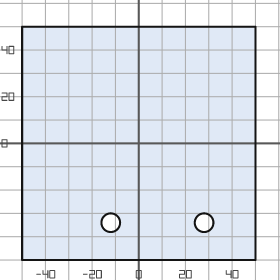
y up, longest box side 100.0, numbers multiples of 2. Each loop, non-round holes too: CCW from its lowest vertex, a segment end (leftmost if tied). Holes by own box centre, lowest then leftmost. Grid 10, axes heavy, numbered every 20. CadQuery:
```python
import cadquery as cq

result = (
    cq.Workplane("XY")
    .moveTo(-50.0, -50.0)
    .lineTo(50.0, -50.0)
    .lineTo(50.0, 50.0)
    .lineTo(-50.0, 50.0)
    .close()
    .moveTo(-12.0, -34.0)
    .circle(4.0)
    .moveTo(28.0, -34.0)
    .circle(4.0)
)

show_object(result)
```